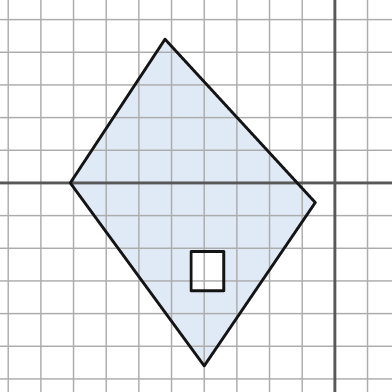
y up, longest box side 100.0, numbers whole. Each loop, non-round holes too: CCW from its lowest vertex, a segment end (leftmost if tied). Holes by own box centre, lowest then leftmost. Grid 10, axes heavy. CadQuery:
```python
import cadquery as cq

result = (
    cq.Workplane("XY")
    .moveTo(-40.0, -56.0)
    .lineTo(-6.0, -6.0)
    .lineTo(-52.0, 44.0)
    .lineTo(-81.0, 0.0)
    .close()
    .moveTo(-44.0, -33.0)
    .lineTo(-34.0, -33.0)
    .lineTo(-34.0, -21.0)
    .lineTo(-44.0, -21.0)
    .close()
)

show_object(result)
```